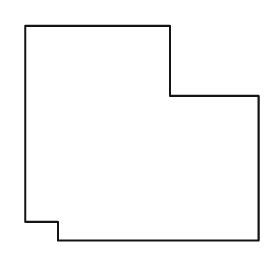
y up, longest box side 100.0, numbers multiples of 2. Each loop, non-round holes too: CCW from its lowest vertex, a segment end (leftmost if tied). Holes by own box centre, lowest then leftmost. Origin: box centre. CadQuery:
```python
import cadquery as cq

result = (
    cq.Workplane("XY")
    .moveTo(-36.0, -46.0)
    .lineTo(50.0, -46.0)
    .lineTo(50.0, 16.0)
    .lineTo(12.0, 16.0)
    .lineTo(12.0, 46.0)
    .lineTo(-50.0, 46.0)
    .lineTo(-50.0, -38.0)
    .lineTo(-36.0, -38.0)
    .close()
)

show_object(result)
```